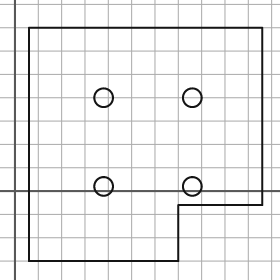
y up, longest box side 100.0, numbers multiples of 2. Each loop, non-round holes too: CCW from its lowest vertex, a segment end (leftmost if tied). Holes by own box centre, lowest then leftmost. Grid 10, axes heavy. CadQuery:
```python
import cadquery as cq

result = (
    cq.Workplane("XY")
    .moveTo(6.0, -30.0)
    .lineTo(70.0, -30.0)
    .lineTo(70.0, -6.0)
    .lineTo(106.0, -6.0)
    .lineTo(106.0, 70.0)
    .lineTo(6.0, 70.0)
    .close()
    .moveTo(38.0, 2.0)
    .circle(4.0)
    .moveTo(76.0, 2.0)
    .circle(4.0)
    .moveTo(38.0, 40.0)
    .circle(4.0)
    .moveTo(76.0, 40.0)
    .circle(4.0)
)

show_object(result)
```